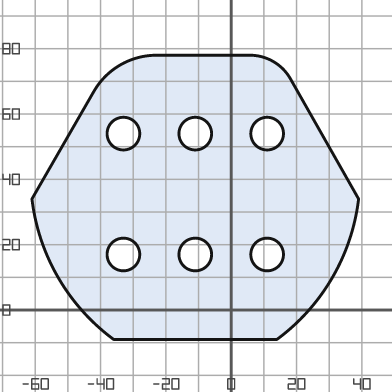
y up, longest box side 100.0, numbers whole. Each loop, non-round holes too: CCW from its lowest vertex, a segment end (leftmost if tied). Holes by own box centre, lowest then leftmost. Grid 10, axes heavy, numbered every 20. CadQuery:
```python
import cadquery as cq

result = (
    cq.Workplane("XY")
    .moveTo(-36.0, -9.0)
    .lineTo(14.0, -9.0)
    .threePointArc((31.0, 10.0), (39.0, 34.0))
    .lineTo(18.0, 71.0)
    .threePointArc((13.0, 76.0), (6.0, 78.0))
    .lineTo(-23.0, 78.0)
    .threePointArc((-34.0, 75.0), (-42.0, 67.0))
    .lineTo(-61.0, 34.0)
    .threePointArc((-53.0, 10.0), (-36.0, -9.0))
    .close()
    .moveTo(-33.0, 17.0)
    .circle(5.0)
    .moveTo(-11.0, 17.0)
    .circle(5.0)
    .moveTo(11.0, 17.0)
    .circle(5.0)
    .moveTo(-33.0, 54.0)
    .circle(5.0)
    .moveTo(-11.0, 54.0)
    .circle(5.0)
    .moveTo(11.0, 54.0)
    .circle(5.0)
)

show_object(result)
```